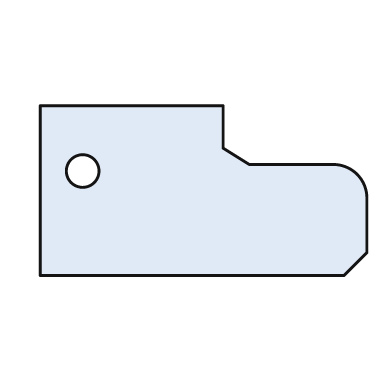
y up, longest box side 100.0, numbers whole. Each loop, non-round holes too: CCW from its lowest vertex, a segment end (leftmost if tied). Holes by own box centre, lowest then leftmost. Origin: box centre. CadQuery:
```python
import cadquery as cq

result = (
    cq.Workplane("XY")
    .moveTo(-50.0, -26.0)
    .lineTo(43.0, -26.0)
    .lineTo(50.0, -19.0)
    .lineTo(50.0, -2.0)
    .threePointArc((47.0, 5.0), (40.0, 8.0))
    .lineTo(14.0, 8.0)
    .lineTo(6.0, 13.0)
    .lineTo(6.0, 26.0)
    .lineTo(-50.0, 26.0)
    .close()
    .moveTo(-37.0, 6.0)
    .circle(5.0)
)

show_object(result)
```